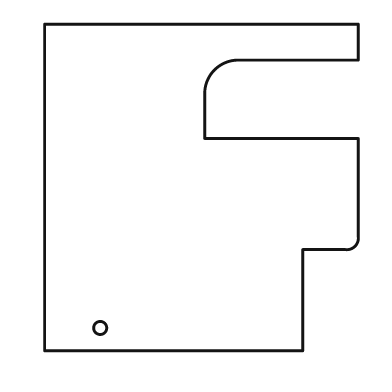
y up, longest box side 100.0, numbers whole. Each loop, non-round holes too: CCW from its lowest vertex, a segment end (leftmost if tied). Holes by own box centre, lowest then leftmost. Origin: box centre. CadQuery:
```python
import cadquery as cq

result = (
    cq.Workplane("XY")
    .moveTo(-48.0, -50.0)
    .lineTo(31.0, -50.0)
    .lineTo(31.0, -19.0)
    .lineTo(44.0, -19.0)
    .threePointArc((47.0, -18.0), (48.0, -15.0))
    .lineTo(48.0, 15.0)
    .lineTo(1.0, 15.0)
    .lineTo(1.0, 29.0)
    .threePointArc((4.0, 36.0), (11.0, 39.0))
    .lineTo(48.0, 39.0)
    .lineTo(48.0, 50.0)
    .lineTo(-48.0, 50.0)
    .close()
    .moveTo(-31.0, -43.0)
    .circle(2.0)
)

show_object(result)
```